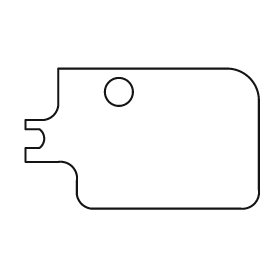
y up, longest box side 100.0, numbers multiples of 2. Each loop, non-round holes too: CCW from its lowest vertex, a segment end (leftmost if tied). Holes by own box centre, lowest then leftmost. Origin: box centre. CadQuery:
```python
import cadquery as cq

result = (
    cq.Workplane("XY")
    .moveTo(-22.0, -30.0)
    .lineTo(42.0, -30.0)
    .threePointArc((48.0, -28.0), (50.0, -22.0))
    .lineTo(50.0, 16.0)
    .threePointArc((46.0, 26.0), (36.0, 30.0))
    .lineTo(-36.0, 30.0)
    .lineTo(-36.0, 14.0)
    .threePointArc((-38.0, 10.0), (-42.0, 8.0))
    .lineTo(-50.0, 8.0)
    .lineTo(-50.0, 4.0)
    .lineTo(-44.0, 4.0)
    .threePointArc((-42.0, 0.0), (-44.0, -4.0))
    .lineTo(-50.0, -4.0)
    .lineTo(-50.0, -10.0)
    .lineTo(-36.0, -10.0)
    .threePointArc((-30.0, -12.0), (-28.0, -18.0))
    .lineTo(-28.0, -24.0)
    .threePointArc((-26.0, -28.0), (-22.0, -30.0))
    .close()
    .moveTo(-10.0, 20.0)
    .circle(6.0)
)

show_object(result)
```